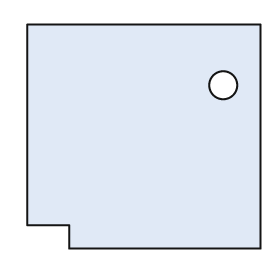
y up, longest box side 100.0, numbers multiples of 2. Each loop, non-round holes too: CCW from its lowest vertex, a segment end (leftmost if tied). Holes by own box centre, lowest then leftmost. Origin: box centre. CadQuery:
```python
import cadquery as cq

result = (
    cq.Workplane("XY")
    .moveTo(-32.0, -48.0)
    .lineTo(50.0, -48.0)
    .lineTo(50.0, 48.0)
    .lineTo(-50.0, 48.0)
    .lineTo(-50.0, -38.0)
    .lineTo(-32.0, -38.0)
    .close()
    .moveTo(34.0, 22.0)
    .circle(6.0)
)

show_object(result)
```